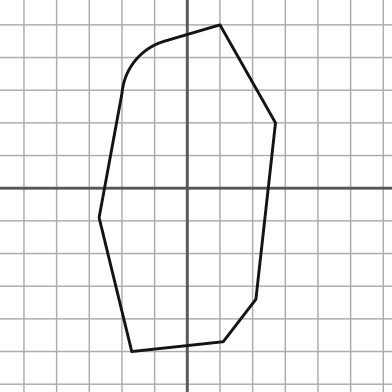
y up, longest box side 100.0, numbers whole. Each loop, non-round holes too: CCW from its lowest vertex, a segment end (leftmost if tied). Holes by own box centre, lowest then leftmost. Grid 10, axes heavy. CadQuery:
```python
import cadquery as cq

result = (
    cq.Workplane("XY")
    .moveTo(-17.0, -50.0)
    .lineTo(11.0, -47.0)
    .lineTo(21.0, -34.0)
    .lineTo(27.0, 20.0)
    .lineTo(10.0, 50.0)
    .lineTo(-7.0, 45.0)
    .threePointArc((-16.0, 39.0), (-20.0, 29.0))
    .lineTo(-27.0, -9.0)
    .close()
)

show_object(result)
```